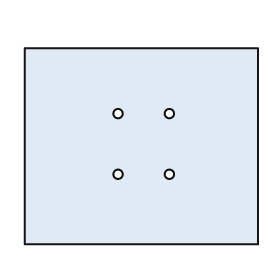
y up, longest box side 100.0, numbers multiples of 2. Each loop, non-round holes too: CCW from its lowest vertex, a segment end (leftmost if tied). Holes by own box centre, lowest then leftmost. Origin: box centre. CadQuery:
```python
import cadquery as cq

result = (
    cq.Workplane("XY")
    .moveTo(-50.0, -42.0)
    .lineTo(50.0, -42.0)
    .lineTo(50.0, 42.0)
    .lineTo(-50.0, 42.0)
    .close()
    .moveTo(-10.0, -12.0)
    .circle(2.0)
    .moveTo(12.0, -12.0)
    .circle(2.0)
    .moveTo(-10.0, 14.0)
    .circle(2.0)
    .moveTo(12.0, 14.0)
    .circle(2.0)
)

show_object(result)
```